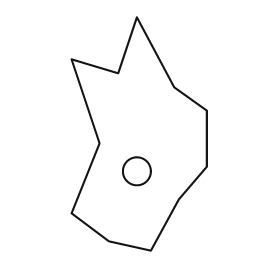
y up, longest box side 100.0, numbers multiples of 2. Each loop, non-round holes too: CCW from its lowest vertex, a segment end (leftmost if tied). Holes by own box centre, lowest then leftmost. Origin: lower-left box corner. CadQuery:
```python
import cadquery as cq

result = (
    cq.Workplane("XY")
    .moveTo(34.0, 0.0)
    .lineTo(46.0, 22.0)
    .lineTo(58.0, 36.0)
    .lineTo(58.0, 60.0)
    .lineTo(44.0, 70.0)
    .lineTo(28.0, 100.0)
    .lineTo(20.0, 76.0)
    .lineTo(0.0, 82.0)
    .lineTo(12.0, 46.0)
    .lineTo(0.0, 16.0)
    .lineTo(16.0, 4.0)
    .close()
    .moveTo(28.0, 34.0)
    .circle(6.0)
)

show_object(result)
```